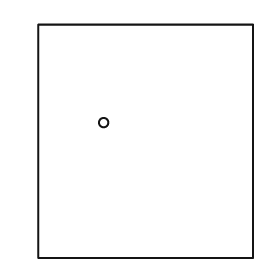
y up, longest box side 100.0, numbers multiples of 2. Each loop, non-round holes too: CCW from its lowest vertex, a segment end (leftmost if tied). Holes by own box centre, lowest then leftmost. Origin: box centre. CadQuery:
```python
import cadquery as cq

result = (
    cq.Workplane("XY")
    .moveTo(-46.0, -50.0)
    .lineTo(46.0, -50.0)
    .lineTo(46.0, 50.0)
    .lineTo(-46.0, 50.0)
    .close()
    .moveTo(-18.0, 8.0)
    .circle(2.0)
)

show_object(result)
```